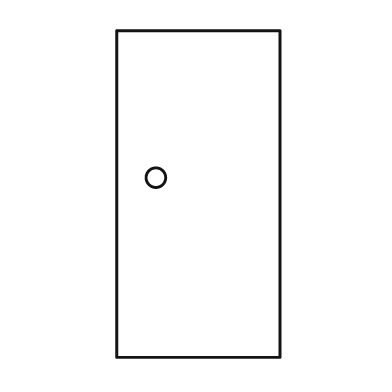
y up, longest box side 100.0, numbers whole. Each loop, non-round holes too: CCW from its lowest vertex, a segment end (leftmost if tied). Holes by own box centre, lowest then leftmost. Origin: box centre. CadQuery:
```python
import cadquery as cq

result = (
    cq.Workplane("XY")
    .moveTo(-25.0, -50.0)
    .lineTo(25.0, -50.0)
    .lineTo(25.0, 50.0)
    .lineTo(-25.0, 50.0)
    .close()
    .moveTo(-13.0, 5.0)
    .circle(3.0)
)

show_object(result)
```